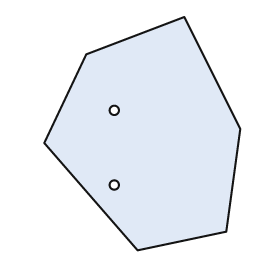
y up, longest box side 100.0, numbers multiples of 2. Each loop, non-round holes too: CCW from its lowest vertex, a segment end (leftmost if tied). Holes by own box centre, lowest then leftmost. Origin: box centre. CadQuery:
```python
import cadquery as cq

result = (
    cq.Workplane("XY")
    .moveTo(-2.0, -50.0)
    .lineTo(36.0, -42.0)
    .lineTo(42.0, 2.0)
    .lineTo(18.0, 50.0)
    .lineTo(-24.0, 34.0)
    .lineTo(-42.0, -4.0)
    .close()
    .moveTo(-12.0, -22.0)
    .circle(2.0)
    .moveTo(-12.0, 10.0)
    .circle(2.0)
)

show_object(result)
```